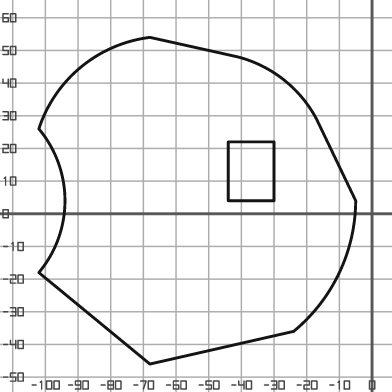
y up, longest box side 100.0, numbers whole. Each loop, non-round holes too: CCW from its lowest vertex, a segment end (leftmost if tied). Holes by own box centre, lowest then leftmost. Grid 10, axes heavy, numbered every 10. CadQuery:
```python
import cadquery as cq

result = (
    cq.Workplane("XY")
    .moveTo(-68.0, -46.0)
    .lineTo(-24.0, -36.0)
    .threePointArc((-10.0, -18.0), (-5.0, 4.0))
    .lineTo(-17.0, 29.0)
    .threePointArc((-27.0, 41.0), (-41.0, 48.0))
    .lineTo(-68.0, 54.0)
    .threePointArc((-89.0, 45.0), (-102.0, 26.0))
    .threePointArc((-94.0, 4.0), (-102.0, -18.0))
    .close()
    .moveTo(-44.0, 4.0)
    .lineTo(-30.0, 4.0)
    .lineTo(-30.0, 22.0)
    .lineTo(-44.0, 22.0)
    .close()
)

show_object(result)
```